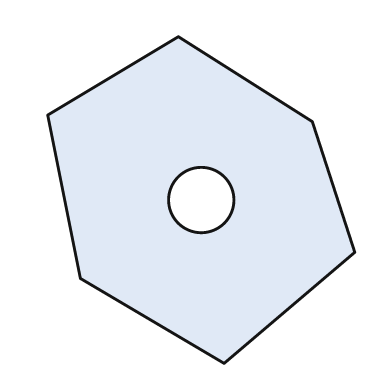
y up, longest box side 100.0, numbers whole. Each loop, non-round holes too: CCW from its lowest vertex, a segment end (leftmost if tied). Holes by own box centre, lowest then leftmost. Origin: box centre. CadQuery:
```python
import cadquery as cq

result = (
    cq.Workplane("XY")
    .moveTo(7.0, -50.0)
    .lineTo(47.0, -16.0)
    .lineTo(34.0, 24.0)
    .lineTo(-7.0, 50.0)
    .lineTo(-47.0, 26.0)
    .lineTo(-37.0, -24.0)
    .close()
    .moveTo(0.0, 0.0)
    .circle(10.0)
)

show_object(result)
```